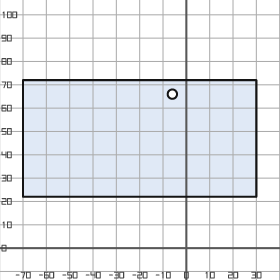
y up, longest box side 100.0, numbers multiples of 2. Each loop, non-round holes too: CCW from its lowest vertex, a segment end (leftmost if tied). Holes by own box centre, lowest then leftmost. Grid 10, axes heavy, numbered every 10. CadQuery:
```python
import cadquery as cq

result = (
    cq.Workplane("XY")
    .moveTo(-70.0, 22.0)
    .lineTo(30.0, 22.0)
    .lineTo(30.0, 72.0)
    .lineTo(-70.0, 72.0)
    .close()
    .moveTo(-6.0, 66.0)
    .circle(2.0)
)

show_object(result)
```